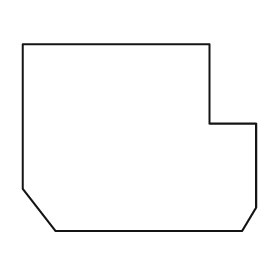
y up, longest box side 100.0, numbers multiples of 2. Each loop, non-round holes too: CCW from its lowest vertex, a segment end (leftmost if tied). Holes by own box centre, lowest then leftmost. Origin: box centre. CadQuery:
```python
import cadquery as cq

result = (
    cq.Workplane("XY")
    .moveTo(-36.0, -40.0)
    .lineTo(44.0, -40.0)
    .lineTo(50.0, -30.0)
    .lineTo(50.0, 6.0)
    .lineTo(30.0, 6.0)
    .lineTo(30.0, 40.0)
    .lineTo(-50.0, 40.0)
    .lineTo(-50.0, -22.0)
    .close()
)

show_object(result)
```